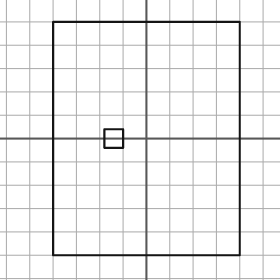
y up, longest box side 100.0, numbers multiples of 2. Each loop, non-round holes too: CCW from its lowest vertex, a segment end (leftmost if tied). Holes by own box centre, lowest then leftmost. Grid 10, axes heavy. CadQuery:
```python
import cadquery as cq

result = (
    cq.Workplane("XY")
    .moveTo(-40.0, -50.0)
    .lineTo(40.0, -50.0)
    .lineTo(40.0, 50.0)
    .lineTo(-40.0, 50.0)
    .close()
    .moveTo(-18.0, -4.0)
    .lineTo(-10.0, -4.0)
    .lineTo(-10.0, 4.0)
    .lineTo(-18.0, 4.0)
    .close()
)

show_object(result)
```